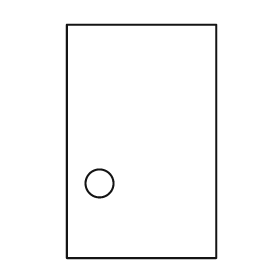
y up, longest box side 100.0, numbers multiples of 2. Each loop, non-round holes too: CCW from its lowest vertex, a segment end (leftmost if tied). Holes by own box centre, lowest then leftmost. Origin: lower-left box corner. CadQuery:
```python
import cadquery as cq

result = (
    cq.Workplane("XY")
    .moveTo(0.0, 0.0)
    .lineTo(64.0, 0.0)
    .lineTo(64.0, 100.0)
    .lineTo(0.0, 100.0)
    .close()
    .moveTo(14.0, 32.0)
    .circle(6.0)
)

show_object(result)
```